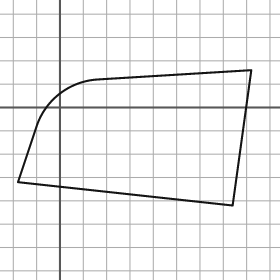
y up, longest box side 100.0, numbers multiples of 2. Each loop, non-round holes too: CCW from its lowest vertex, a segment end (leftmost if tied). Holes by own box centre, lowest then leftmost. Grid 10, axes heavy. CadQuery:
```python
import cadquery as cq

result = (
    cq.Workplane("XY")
    .moveTo(74.0, -42.0)
    .lineTo(82.0, 16.0)
    .lineTo(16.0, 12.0)
    .threePointArc((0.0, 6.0), (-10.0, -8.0))
    .lineTo(-18.0, -32.0)
    .close()
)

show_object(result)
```